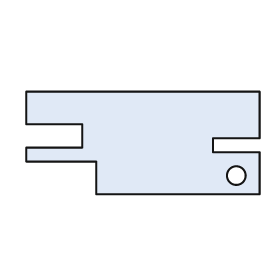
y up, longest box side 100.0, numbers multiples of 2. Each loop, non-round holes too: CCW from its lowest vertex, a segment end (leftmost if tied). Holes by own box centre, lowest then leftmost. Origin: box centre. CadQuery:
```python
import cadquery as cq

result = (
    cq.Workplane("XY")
    .moveTo(-20.0, -22.0)
    .lineTo(50.0, -22.0)
    .lineTo(50.0, -4.0)
    .lineTo(30.0, -4.0)
    .lineTo(30.0, 2.0)
    .lineTo(50.0, 2.0)
    .lineTo(50.0, 22.0)
    .lineTo(-50.0, 22.0)
    .lineTo(-50.0, 8.0)
    .lineTo(-26.0, 8.0)
    .lineTo(-26.0, -2.0)
    .lineTo(-50.0, -2.0)
    .lineTo(-50.0, -8.0)
    .lineTo(-20.0, -8.0)
    .close()
    .moveTo(40.0, -14.0)
    .circle(4.0)
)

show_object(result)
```